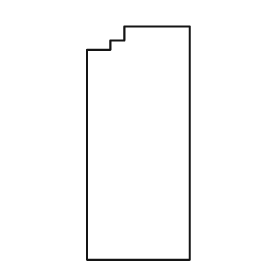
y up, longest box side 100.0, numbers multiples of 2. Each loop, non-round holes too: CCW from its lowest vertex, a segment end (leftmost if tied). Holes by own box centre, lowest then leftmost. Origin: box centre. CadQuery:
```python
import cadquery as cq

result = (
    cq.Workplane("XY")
    .moveTo(-22.0, -50.0)
    .lineTo(22.0, -50.0)
    .lineTo(22.0, 50.0)
    .lineTo(-6.0, 50.0)
    .lineTo(-6.0, 44.0)
    .lineTo(-12.0, 44.0)
    .lineTo(-12.0, 40.0)
    .lineTo(-22.0, 40.0)
    .close()
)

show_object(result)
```